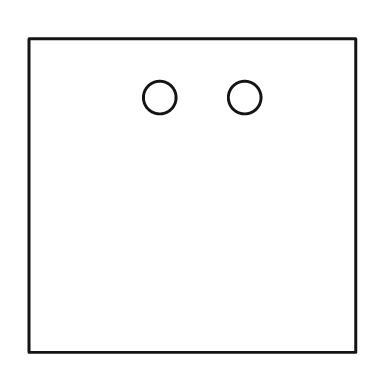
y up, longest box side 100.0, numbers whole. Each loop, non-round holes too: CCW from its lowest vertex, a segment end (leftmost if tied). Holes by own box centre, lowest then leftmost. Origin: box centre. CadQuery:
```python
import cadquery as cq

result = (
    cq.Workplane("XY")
    .moveTo(-50.0, -48.0)
    .lineTo(50.0, -48.0)
    .lineTo(50.0, 48.0)
    .lineTo(-50.0, 48.0)
    .close()
    .moveTo(-10.0, 30.0)
    .circle(5.0)
    .moveTo(16.0, 30.0)
    .circle(5.0)
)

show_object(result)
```